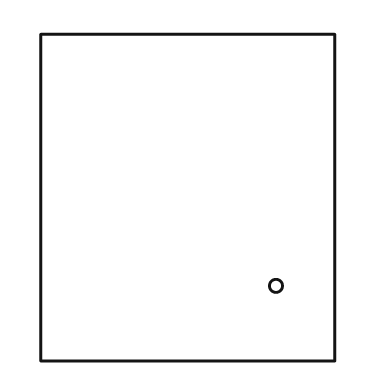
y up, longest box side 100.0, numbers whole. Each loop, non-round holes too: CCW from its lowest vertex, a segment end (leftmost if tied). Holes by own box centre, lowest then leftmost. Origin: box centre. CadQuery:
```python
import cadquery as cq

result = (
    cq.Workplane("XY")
    .moveTo(-45.0, -50.0)
    .lineTo(45.0, -50.0)
    .lineTo(45.0, 50.0)
    .lineTo(-45.0, 50.0)
    .close()
    .moveTo(27.0, -27.0)
    .circle(2.0)
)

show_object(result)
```